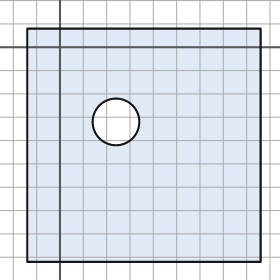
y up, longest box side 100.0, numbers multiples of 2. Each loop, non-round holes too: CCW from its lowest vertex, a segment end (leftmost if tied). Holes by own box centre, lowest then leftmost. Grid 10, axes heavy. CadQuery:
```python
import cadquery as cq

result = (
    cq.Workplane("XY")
    .moveTo(-14.0, -92.0)
    .lineTo(86.0, -92.0)
    .lineTo(86.0, 8.0)
    .lineTo(-14.0, 8.0)
    .close()
    .moveTo(24.0, -32.0)
    .circle(10.0)
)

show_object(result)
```